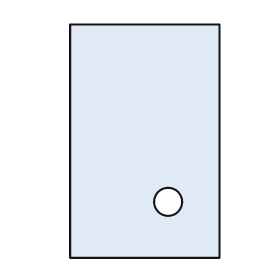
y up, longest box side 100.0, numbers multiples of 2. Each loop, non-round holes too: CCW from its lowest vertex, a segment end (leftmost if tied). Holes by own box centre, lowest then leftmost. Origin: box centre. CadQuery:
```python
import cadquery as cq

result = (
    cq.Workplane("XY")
    .moveTo(-32.0, -50.0)
    .lineTo(32.0, -50.0)
    .lineTo(32.0, 50.0)
    .lineTo(-32.0, 50.0)
    .close()
    .moveTo(10.0, -26.0)
    .circle(6.0)
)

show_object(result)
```